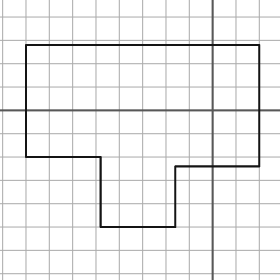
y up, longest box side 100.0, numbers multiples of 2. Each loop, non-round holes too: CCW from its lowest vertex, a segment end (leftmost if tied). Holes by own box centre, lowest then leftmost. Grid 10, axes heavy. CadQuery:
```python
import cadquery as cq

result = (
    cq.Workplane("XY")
    .moveTo(-48.0, -50.0)
    .lineTo(-16.0, -50.0)
    .lineTo(-16.0, -24.0)
    .lineTo(20.0, -24.0)
    .lineTo(20.0, 28.0)
    .lineTo(-80.0, 28.0)
    .lineTo(-80.0, -20.0)
    .lineTo(-48.0, -20.0)
    .close()
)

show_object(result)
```